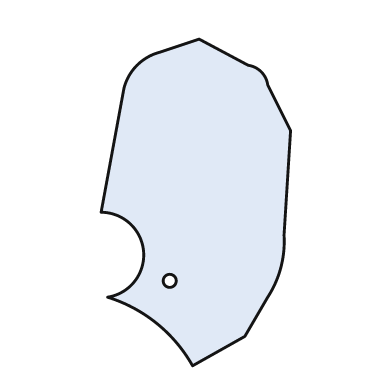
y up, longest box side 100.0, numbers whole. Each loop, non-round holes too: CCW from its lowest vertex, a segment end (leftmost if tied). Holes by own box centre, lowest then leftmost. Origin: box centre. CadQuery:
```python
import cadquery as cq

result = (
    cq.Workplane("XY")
    .moveTo(-1.0, -50.0)
    .lineTo(15.0, -41.0)
    .lineTo(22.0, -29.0)
    .threePointArc((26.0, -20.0), (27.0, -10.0))
    .lineTo(29.0, 22.0)
    .lineTo(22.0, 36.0)
    .threePointArc((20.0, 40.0), (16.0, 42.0))
    .lineTo(1.0, 50.0)
    .lineTo(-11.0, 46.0)
    .threePointArc((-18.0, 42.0), (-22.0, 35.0))
    .lineTo(-29.0, -3.0)
    .threePointArc((-16.0, -15.0), (-27.0, -29.0))
    .threePointArc((-12.0, -37.0), (-1.0, -50.0))
    .close()
    .moveTo(-8.0, -24.0)
    .circle(2.0)
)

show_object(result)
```